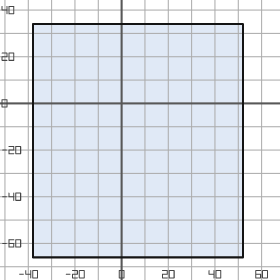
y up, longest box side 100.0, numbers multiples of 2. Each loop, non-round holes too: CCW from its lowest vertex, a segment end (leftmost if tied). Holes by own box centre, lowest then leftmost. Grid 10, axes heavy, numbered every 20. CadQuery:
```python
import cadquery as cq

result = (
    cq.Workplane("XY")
    .moveTo(-38.0, -66.0)
    .lineTo(52.0, -66.0)
    .lineTo(52.0, 34.0)
    .lineTo(-38.0, 34.0)
    .close()
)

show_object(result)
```